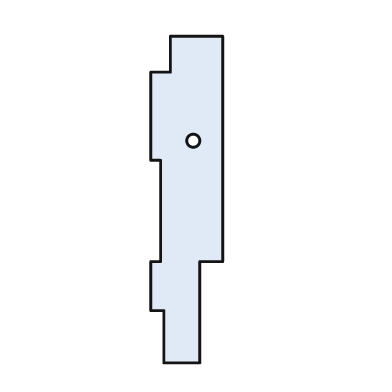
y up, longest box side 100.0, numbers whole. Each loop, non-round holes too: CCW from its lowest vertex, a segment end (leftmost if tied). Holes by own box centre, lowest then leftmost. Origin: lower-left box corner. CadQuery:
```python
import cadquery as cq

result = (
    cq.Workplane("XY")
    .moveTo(4.0, 0.0)
    .lineTo(15.0, 0.0)
    .lineTo(15.0, 31.0)
    .lineTo(22.0, 31.0)
    .lineTo(22.0, 100.0)
    .lineTo(6.0, 100.0)
    .lineTo(6.0, 89.0)
    .lineTo(0.0, 89.0)
    .lineTo(0.0, 62.0)
    .lineTo(3.0, 62.0)
    .lineTo(3.0, 31.0)
    .lineTo(0.0, 31.0)
    .lineTo(0.0, 16.0)
    .lineTo(4.0, 16.0)
    .close()
    .moveTo(13.0, 68.0)
    .circle(2.0)
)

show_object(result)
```